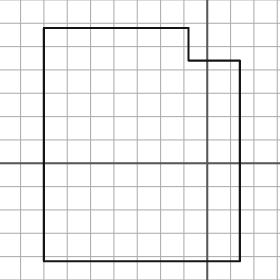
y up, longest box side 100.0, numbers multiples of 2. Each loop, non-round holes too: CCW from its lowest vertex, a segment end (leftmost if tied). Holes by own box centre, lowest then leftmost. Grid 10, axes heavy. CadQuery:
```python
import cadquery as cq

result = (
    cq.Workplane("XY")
    .moveTo(-70.0, -42.0)
    .lineTo(14.0, -42.0)
    .lineTo(14.0, 44.0)
    .lineTo(-8.0, 44.0)
    .lineTo(-8.0, 58.0)
    .lineTo(-70.0, 58.0)
    .close()
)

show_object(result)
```